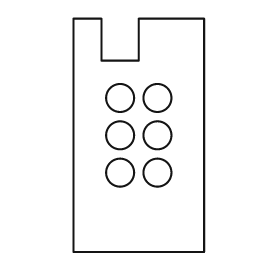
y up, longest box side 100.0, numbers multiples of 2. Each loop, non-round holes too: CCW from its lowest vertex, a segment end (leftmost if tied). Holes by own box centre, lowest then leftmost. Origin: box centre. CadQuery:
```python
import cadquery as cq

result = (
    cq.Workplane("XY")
    .moveTo(-28.0, -50.0)
    .lineTo(28.0, -50.0)
    .lineTo(28.0, 50.0)
    .lineTo(0.0, 50.0)
    .lineTo(0.0, 32.0)
    .lineTo(-16.0, 32.0)
    .lineTo(-16.0, 50.0)
    .lineTo(-28.0, 50.0)
    .close()
    .moveTo(-8.0, -16.0)
    .circle(6.0)
    .moveTo(8.0, -16.0)
    .circle(6.0)
    .moveTo(-8.0, 0.0)
    .circle(6.0)
    .moveTo(8.0, 0.0)
    .circle(6.0)
    .moveTo(-8.0, 16.0)
    .circle(6.0)
    .moveTo(8.0, 16.0)
    .circle(6.0)
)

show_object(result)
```